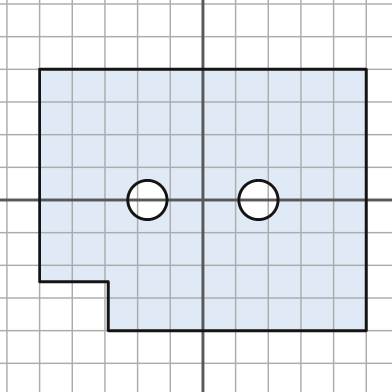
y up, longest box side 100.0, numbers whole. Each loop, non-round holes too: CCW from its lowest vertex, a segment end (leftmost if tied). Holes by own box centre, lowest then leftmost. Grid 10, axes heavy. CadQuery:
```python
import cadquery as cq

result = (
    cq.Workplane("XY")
    .moveTo(-29.0, -40.0)
    .lineTo(50.0, -40.0)
    .lineTo(50.0, 40.0)
    .lineTo(-50.0, 40.0)
    .lineTo(-50.0, -25.0)
    .lineTo(-29.0, -25.0)
    .close()
    .moveTo(-17.0, 0.0)
    .circle(6.0)
    .moveTo(17.0, 0.0)
    .circle(6.0)
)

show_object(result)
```